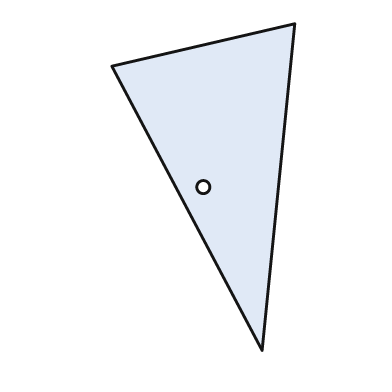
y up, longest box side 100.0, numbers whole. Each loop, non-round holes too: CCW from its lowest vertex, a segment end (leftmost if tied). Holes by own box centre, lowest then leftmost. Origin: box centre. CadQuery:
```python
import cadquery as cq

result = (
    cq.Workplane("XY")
    .moveTo(18.0, -50.0)
    .lineTo(28.0, 50.0)
    .lineTo(-28.0, 37.0)
    .close()
    .moveTo(0.0, 0.0)
    .circle(2.0)
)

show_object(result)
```